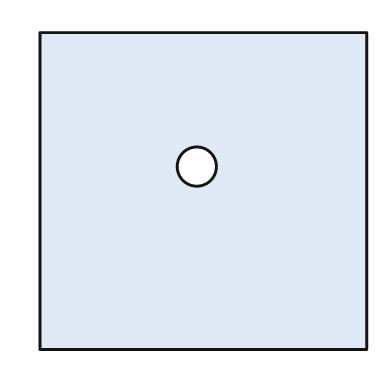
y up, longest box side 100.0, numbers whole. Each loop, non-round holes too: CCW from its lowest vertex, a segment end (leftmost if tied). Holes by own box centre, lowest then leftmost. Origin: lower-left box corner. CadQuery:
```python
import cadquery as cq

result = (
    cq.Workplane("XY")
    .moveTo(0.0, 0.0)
    .lineTo(100.0, 0.0)
    .lineTo(100.0, 97.0)
    .lineTo(0.0, 97.0)
    .close()
    .moveTo(48.0, 56.0)
    .circle(6.0)
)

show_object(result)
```